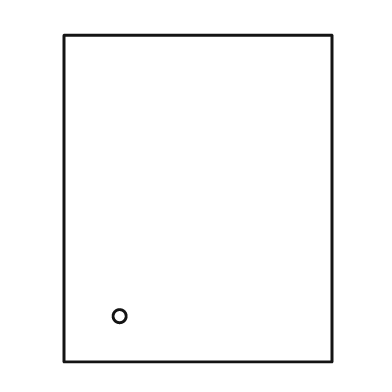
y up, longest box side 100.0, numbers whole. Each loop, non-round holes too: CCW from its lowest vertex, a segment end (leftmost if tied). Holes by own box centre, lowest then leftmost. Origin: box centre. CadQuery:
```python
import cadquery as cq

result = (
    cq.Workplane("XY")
    .moveTo(-41.0, -50.0)
    .lineTo(41.0, -50.0)
    .lineTo(41.0, 50.0)
    .lineTo(-41.0, 50.0)
    .close()
    .moveTo(-24.0, -36.0)
    .circle(2.0)
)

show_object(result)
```